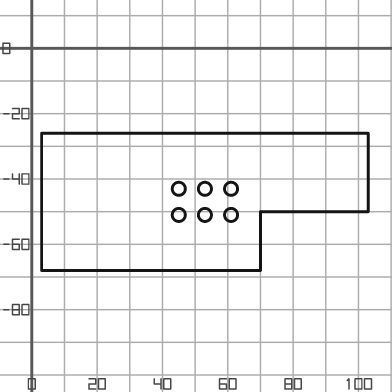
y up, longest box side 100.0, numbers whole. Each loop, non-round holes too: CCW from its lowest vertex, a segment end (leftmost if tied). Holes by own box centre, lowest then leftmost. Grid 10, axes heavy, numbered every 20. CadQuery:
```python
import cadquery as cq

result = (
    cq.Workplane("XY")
    .moveTo(3.0, -68.0)
    .lineTo(70.0, -68.0)
    .lineTo(70.0, -50.0)
    .lineTo(103.0, -50.0)
    .lineTo(103.0, -26.0)
    .lineTo(3.0, -26.0)
    .close()
    .moveTo(45.0, -51.0)
    .circle(2.0)
    .moveTo(53.0, -51.0)
    .circle(2.0)
    .moveTo(61.0, -51.0)
    .circle(2.0)
    .moveTo(45.0, -43.0)
    .circle(2.0)
    .moveTo(53.0, -43.0)
    .circle(2.0)
    .moveTo(61.0, -43.0)
    .circle(2.0)
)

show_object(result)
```